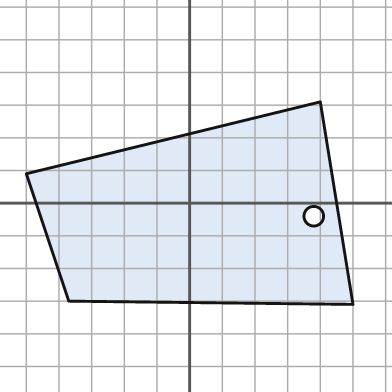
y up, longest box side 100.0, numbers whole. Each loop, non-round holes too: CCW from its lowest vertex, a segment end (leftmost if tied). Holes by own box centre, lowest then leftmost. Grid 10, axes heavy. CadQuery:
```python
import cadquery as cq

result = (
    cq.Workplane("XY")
    .moveTo(50.0, -31.0)
    .lineTo(40.0, 31.0)
    .lineTo(-50.0, 9.0)
    .lineTo(-37.0, -30.0)
    .close()
    .moveTo(38.0, -4.0)
    .circle(3.0)
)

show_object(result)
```